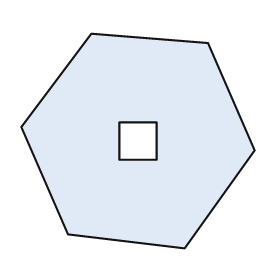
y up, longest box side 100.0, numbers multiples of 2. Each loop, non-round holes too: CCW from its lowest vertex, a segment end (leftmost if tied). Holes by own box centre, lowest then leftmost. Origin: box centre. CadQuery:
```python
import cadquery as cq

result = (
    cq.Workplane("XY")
    .moveTo(20.0, -46.0)
    .lineTo(50.0, -4.0)
    .lineTo(30.0, 42.0)
    .lineTo(-20.0, 46.0)
    .lineTo(-50.0, 6.0)
    .lineTo(-30.0, -40.0)
    .close()
    .moveTo(-8.0, -8.0)
    .lineTo(8.0, -8.0)
    .lineTo(8.0, 8.0)
    .lineTo(-8.0, 8.0)
    .close()
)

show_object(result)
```